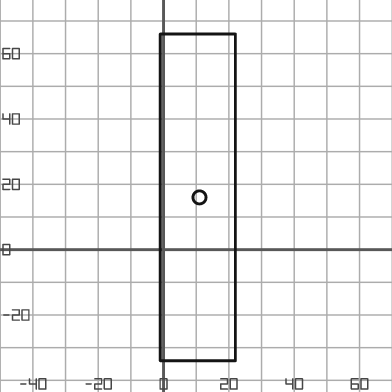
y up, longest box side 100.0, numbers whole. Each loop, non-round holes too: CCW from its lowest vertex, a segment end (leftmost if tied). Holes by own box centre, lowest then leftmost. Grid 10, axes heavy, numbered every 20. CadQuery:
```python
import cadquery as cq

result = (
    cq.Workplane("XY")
    .moveTo(-1.0, -34.0)
    .lineTo(22.0, -34.0)
    .lineTo(22.0, 66.0)
    .lineTo(-1.0, 66.0)
    .close()
    .moveTo(11.0, 16.0)
    .circle(2.0)
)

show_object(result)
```